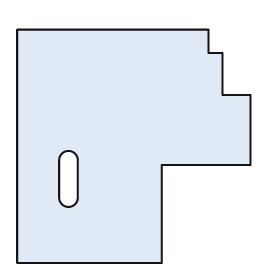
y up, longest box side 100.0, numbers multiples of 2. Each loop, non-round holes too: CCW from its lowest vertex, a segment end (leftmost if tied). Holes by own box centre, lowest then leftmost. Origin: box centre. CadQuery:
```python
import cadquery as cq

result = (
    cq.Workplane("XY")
    .moveTo(-50.0, -50.0)
    .lineTo(12.0, -50.0)
    .lineTo(12.0, -8.0)
    .lineTo(50.0, -8.0)
    .lineTo(50.0, 22.0)
    .lineTo(38.0, 22.0)
    .lineTo(38.0, 40.0)
    .lineTo(32.0, 40.0)
    .lineTo(32.0, 50.0)
    .lineTo(-50.0, 50.0)
    .close()
    .moveTo(-32.0, -22.0)
    .threePointArc((-28.0, -26.0), (-24.0, -22.0))
    .lineTo(-24.0, -6.0)
    .threePointArc((-28.0, -2.0), (-32.0, -6.0))
    .close()
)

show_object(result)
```